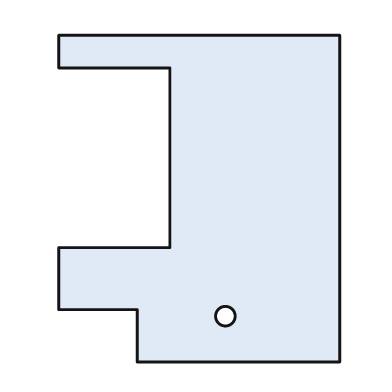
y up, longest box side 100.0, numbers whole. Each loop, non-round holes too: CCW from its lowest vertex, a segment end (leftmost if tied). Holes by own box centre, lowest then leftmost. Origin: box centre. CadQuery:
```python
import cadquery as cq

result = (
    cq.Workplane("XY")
    .moveTo(-19.0, -50.0)
    .lineTo(43.0, -50.0)
    .lineTo(43.0, 50.0)
    .lineTo(-43.0, 50.0)
    .lineTo(-43.0, 40.0)
    .lineTo(-9.0, 40.0)
    .lineTo(-9.0, -15.0)
    .lineTo(-43.0, -15.0)
    .lineTo(-43.0, -34.0)
    .lineTo(-19.0, -34.0)
    .close()
    .moveTo(8.0, -36.0)
    .circle(3.0)
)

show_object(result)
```